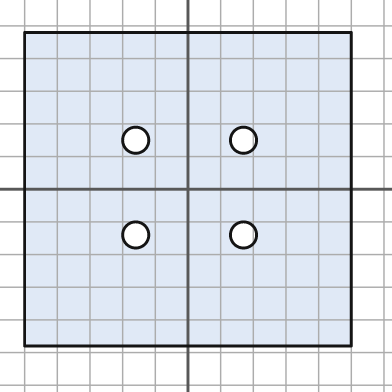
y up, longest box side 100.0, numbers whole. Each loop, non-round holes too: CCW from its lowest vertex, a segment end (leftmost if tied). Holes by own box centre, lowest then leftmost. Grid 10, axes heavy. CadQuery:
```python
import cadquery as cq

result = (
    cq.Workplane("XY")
    .moveTo(-50.0, -48.0)
    .lineTo(50.0, -48.0)
    .lineTo(50.0, 48.0)
    .lineTo(-50.0, 48.0)
    .close()
    .moveTo(-16.0, -14.0)
    .circle(4.0)
    .moveTo(17.0, -14.0)
    .circle(4.0)
    .moveTo(-16.0, 15.0)
    .circle(4.0)
    .moveTo(17.0, 15.0)
    .circle(4.0)
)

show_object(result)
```